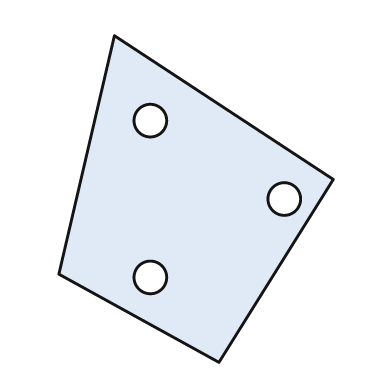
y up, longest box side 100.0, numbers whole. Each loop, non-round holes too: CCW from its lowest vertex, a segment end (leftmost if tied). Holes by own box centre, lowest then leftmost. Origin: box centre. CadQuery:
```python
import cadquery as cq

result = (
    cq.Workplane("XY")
    .moveTo(7.0, -50.0)
    .lineTo(42.0, 6.0)
    .lineTo(-25.0, 50.0)
    .lineTo(-42.0, -23.0)
    .close()
    .moveTo(-14.0, -24.0)
    .circle(5.0)
    .moveTo(27.0, 0.0)
    .circle(5.0)
    .moveTo(-14.0, 24.0)
    .circle(5.0)
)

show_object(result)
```